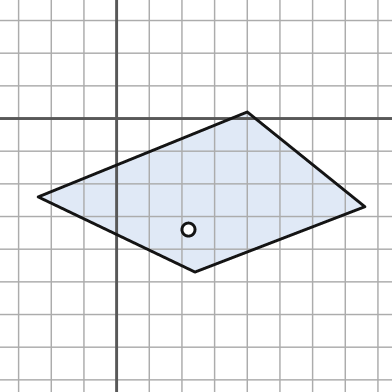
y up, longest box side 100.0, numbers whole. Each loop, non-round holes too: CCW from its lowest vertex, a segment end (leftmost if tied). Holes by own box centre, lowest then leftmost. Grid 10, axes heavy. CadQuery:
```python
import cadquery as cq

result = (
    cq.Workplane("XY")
    .moveTo(24.0, -47.0)
    .lineTo(76.0, -27.0)
    .lineTo(40.0, 2.0)
    .lineTo(-24.0, -24.0)
    .close()
    .moveTo(22.0, -34.0)
    .circle(2.0)
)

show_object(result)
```